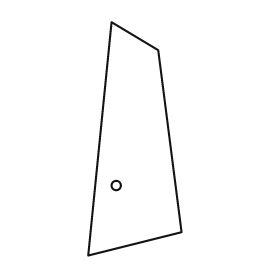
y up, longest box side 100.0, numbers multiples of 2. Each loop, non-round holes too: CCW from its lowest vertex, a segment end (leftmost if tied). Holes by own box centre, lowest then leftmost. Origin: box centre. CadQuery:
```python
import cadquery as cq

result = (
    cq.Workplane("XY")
    .moveTo(-20.0, -50.0)
    .lineTo(20.0, -40.0)
    .lineTo(10.0, 38.0)
    .lineTo(-10.0, 50.0)
    .close()
    .moveTo(-8.0, -20.0)
    .circle(2.0)
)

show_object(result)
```